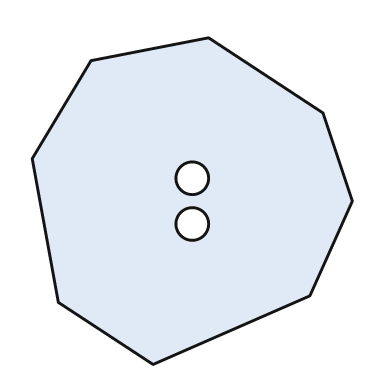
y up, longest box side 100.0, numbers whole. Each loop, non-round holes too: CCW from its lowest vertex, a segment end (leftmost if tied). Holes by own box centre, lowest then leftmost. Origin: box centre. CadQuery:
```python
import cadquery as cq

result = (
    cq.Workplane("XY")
    .moveTo(-12.0, -50.0)
    .lineTo(36.0, -29.0)
    .lineTo(49.0, 0.0)
    .lineTo(40.0, 27.0)
    .lineTo(5.0, 50.0)
    .lineTo(-31.0, 43.0)
    .lineTo(-49.0, 13.0)
    .lineTo(-41.0, -31.0)
    .close()
    .moveTo(0.0, -7.0)
    .circle(5.0)
    .moveTo(0.0, 7.0)
    .circle(5.0)
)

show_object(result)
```